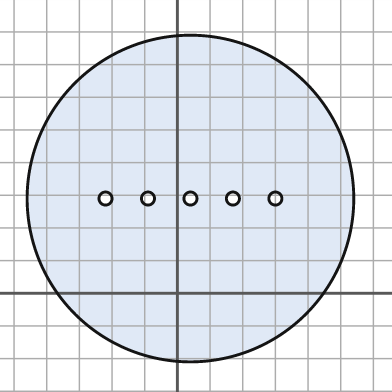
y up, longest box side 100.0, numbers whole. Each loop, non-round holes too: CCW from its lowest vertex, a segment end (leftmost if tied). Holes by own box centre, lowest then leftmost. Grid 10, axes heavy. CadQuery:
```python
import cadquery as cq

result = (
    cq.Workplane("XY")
    .moveTo(4.0, 29.0)
    .circle(50.0)
    .moveTo(-22.0, 29.0)
    .circle(2.0)
    .moveTo(-9.0, 29.0)
    .circle(2.0)
    .moveTo(4.0, 29.0)
    .circle(2.0)
    .moveTo(17.0, 29.0)
    .circle(2.0)
    .moveTo(30.0, 29.0)
    .circle(2.0)
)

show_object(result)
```